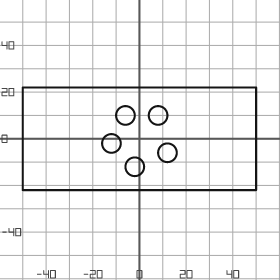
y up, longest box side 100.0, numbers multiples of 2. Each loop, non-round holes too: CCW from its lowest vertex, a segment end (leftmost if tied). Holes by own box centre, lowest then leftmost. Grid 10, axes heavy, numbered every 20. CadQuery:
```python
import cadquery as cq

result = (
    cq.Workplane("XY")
    .moveTo(-50.0, -22.0)
    .lineTo(50.0, -22.0)
    .lineTo(50.0, 22.0)
    .lineTo(-50.0, 22.0)
    .close()
    .moveTo(-2.0, -12.0)
    .circle(4.0)
    .moveTo(12.0, -6.0)
    .circle(4.0)
    .moveTo(-12.0, -2.0)
    .circle(4.0)
    .moveTo(-6.0, 10.0)
    .circle(4.0)
    .moveTo(8.0, 10.0)
    .circle(4.0)
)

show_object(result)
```